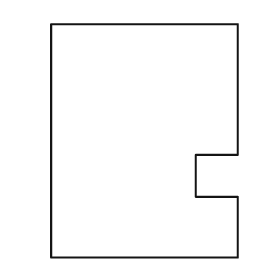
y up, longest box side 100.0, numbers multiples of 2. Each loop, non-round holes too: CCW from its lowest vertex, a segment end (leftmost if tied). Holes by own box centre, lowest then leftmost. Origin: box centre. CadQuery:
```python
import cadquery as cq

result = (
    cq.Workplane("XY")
    .moveTo(-40.0, -50.0)
    .lineTo(40.0, -50.0)
    .lineTo(40.0, -24.0)
    .lineTo(22.0, -24.0)
    .lineTo(22.0, -6.0)
    .lineTo(40.0, -6.0)
    .lineTo(40.0, 50.0)
    .lineTo(-40.0, 50.0)
    .close()
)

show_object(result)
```